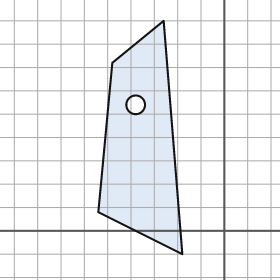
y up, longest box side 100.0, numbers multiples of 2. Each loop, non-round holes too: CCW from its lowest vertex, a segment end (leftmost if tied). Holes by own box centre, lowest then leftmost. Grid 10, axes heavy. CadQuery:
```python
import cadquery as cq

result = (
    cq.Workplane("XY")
    .moveTo(-18.0, -10.0)
    .lineTo(-26.0, 90.0)
    .lineTo(-48.0, 72.0)
    .lineTo(-54.0, 8.0)
    .close()
    .moveTo(-38.0, 54.0)
    .circle(4.0)
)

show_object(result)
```